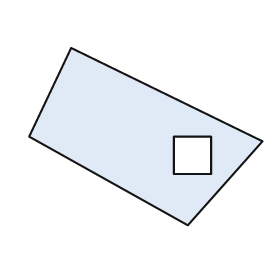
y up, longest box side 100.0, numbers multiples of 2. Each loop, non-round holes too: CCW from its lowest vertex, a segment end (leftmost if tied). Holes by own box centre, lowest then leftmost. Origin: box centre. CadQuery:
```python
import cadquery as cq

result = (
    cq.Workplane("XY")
    .moveTo(18.0, -38.0)
    .lineTo(50.0, -2.0)
    .lineTo(-32.0, 38.0)
    .lineTo(-50.0, 0.0)
    .close()
    .moveTo(12.0, -16.0)
    .lineTo(28.0, -16.0)
    .lineTo(28.0, 0.0)
    .lineTo(12.0, 0.0)
    .close()
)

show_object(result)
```